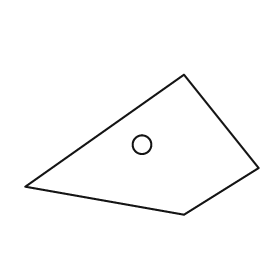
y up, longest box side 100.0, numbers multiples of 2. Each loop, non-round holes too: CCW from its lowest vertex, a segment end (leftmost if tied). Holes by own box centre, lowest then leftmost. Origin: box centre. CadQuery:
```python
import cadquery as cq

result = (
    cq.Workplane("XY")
    .moveTo(18.0, -30.0)
    .lineTo(50.0, -10.0)
    .lineTo(18.0, 30.0)
    .lineTo(-50.0, -18.0)
    .close()
    .moveTo(0.0, 0.0)
    .circle(4.0)
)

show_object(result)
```